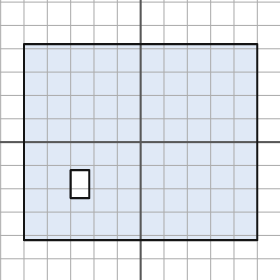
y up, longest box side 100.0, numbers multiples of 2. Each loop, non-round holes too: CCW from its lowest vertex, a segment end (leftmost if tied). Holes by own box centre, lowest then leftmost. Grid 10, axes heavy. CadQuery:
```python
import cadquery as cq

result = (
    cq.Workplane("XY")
    .moveTo(-50.0, -42.0)
    .lineTo(50.0, -42.0)
    .lineTo(50.0, 42.0)
    .lineTo(-50.0, 42.0)
    .close()
    .moveTo(-30.0, -24.0)
    .lineTo(-22.0, -24.0)
    .lineTo(-22.0, -12.0)
    .lineTo(-30.0, -12.0)
    .close()
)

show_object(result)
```